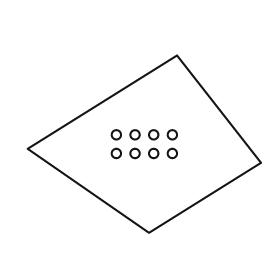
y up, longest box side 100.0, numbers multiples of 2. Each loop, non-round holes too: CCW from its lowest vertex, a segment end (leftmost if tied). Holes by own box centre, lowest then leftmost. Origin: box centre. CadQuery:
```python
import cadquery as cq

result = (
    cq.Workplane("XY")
    .moveTo(2.0, -38.0)
    .lineTo(50.0, -8.0)
    .lineTo(14.0, 38.0)
    .lineTo(-50.0, -2.0)
    .close()
    .moveTo(-12.0, -4.0)
    .circle(2.0)
    .moveTo(-4.0, -4.0)
    .circle(2.0)
    .moveTo(4.0, -4.0)
    .circle(2.0)
    .moveTo(12.0, -4.0)
    .circle(2.0)
    .moveTo(-12.0, 4.0)
    .circle(2.0)
    .moveTo(-4.0, 4.0)
    .circle(2.0)
    .moveTo(4.0, 4.0)
    .circle(2.0)
    .moveTo(12.0, 4.0)
    .circle(2.0)
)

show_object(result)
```